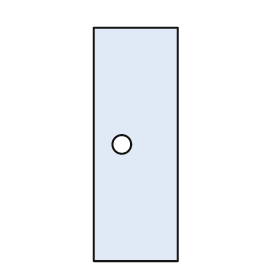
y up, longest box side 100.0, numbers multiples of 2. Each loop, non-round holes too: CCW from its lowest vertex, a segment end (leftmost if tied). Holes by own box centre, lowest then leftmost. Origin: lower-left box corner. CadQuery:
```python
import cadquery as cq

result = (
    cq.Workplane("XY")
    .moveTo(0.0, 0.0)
    .lineTo(36.0, 0.0)
    .lineTo(36.0, 100.0)
    .lineTo(0.0, 100.0)
    .close()
    .moveTo(12.0, 50.0)
    .circle(4.0)
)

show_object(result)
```